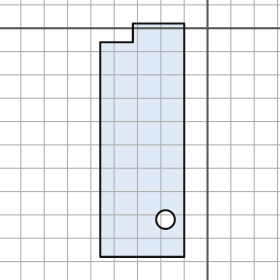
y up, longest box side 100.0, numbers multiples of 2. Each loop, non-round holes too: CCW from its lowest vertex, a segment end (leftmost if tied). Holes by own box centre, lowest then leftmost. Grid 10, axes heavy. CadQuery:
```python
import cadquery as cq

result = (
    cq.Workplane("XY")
    .moveTo(-46.0, -98.0)
    .lineTo(-10.0, -98.0)
    .lineTo(-10.0, 2.0)
    .lineTo(-32.0, 2.0)
    .lineTo(-32.0, -6.0)
    .lineTo(-46.0, -6.0)
    .close()
    .moveTo(-18.0, -82.0)
    .circle(4.0)
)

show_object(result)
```